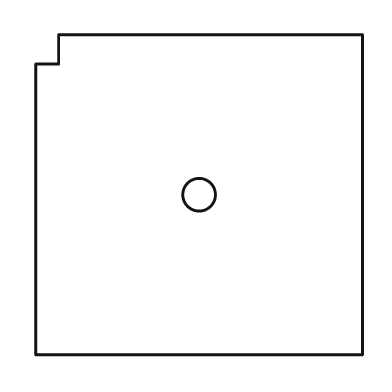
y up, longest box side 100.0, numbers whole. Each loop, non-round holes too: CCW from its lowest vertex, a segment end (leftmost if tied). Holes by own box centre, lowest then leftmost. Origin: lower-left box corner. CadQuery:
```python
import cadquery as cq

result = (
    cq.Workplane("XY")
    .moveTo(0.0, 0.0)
    .lineTo(100.0, 0.0)
    .lineTo(100.0, 98.0)
    .lineTo(7.0, 98.0)
    .lineTo(7.0, 89.0)
    .lineTo(0.0, 89.0)
    .close()
    .moveTo(50.0, 49.0)
    .circle(5.0)
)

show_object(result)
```